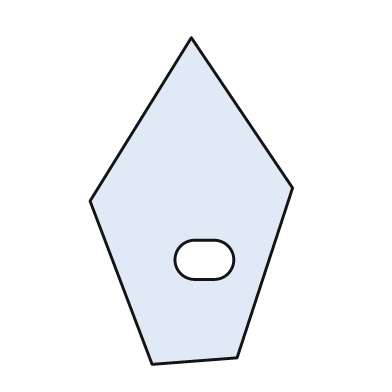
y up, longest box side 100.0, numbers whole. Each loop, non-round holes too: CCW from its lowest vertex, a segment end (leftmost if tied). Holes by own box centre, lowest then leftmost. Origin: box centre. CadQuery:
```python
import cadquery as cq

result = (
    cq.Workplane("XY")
    .moveTo(-12.0, -50.0)
    .lineTo(14.0, -48.0)
    .lineTo(31.0, 4.0)
    .lineTo(0.0, 50.0)
    .lineTo(-31.0, 0.0)
    .close()
    .moveTo(1.0, -24.0)
    .lineTo(7.0, -24.0)
    .threePointArc((13.0, -18.0), (7.0, -12.0))
    .lineTo(1.0, -12.0)
    .threePointArc((-5.0, -18.0), (1.0, -24.0))
    .close()
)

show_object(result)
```